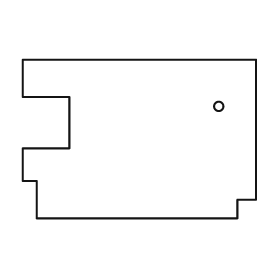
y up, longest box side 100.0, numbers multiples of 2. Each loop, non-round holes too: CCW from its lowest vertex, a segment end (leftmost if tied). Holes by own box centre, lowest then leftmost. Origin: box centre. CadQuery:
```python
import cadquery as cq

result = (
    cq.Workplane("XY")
    .moveTo(-44.0, -34.0)
    .lineTo(42.0, -34.0)
    .lineTo(42.0, -26.0)
    .lineTo(50.0, -26.0)
    .lineTo(50.0, 34.0)
    .lineTo(-50.0, 34.0)
    .lineTo(-50.0, 18.0)
    .lineTo(-30.0, 18.0)
    .lineTo(-30.0, -4.0)
    .lineTo(-50.0, -4.0)
    .lineTo(-50.0, -18.0)
    .lineTo(-44.0, -18.0)
    .close()
    .moveTo(34.0, 14.0)
    .circle(2.0)
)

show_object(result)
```